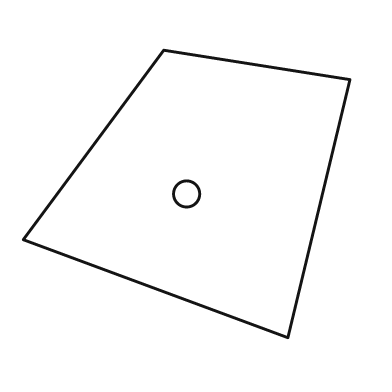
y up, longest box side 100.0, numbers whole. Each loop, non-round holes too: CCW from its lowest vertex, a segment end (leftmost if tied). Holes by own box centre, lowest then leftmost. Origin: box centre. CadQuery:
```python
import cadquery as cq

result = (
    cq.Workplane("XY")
    .moveTo(31.0, -44.0)
    .lineTo(50.0, 35.0)
    .lineTo(-7.0, 44.0)
    .lineTo(-50.0, -14.0)
    .close()
    .moveTo(0.0, 0.0)
    .circle(4.0)
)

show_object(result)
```